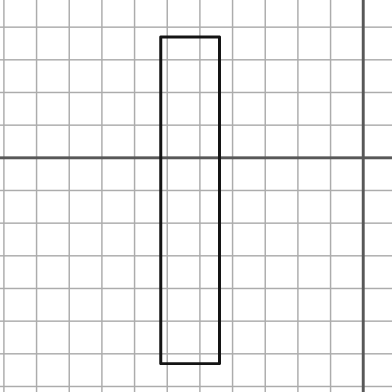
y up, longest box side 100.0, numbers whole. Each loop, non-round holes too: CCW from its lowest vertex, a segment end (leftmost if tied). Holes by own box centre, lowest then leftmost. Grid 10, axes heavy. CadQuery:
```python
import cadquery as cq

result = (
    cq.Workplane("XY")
    .moveTo(-62.0, -63.0)
    .lineTo(-44.0, -63.0)
    .lineTo(-44.0, 37.0)
    .lineTo(-62.0, 37.0)
    .close()
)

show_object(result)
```